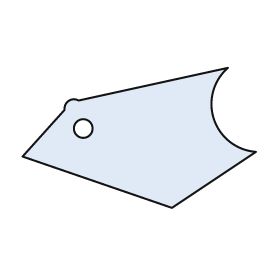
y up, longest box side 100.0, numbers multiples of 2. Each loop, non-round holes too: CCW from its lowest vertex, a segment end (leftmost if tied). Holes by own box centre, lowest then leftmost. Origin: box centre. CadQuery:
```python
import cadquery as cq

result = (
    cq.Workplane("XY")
    .moveTo(14.0, -30.0)
    .lineTo(50.0, -6.0)
    .threePointArc((32.0, 8.0), (38.0, 30.0))
    .lineTo(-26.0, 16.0)
    .threePointArc((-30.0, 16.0), (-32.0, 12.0))
    .lineTo(-50.0, -8.0)
    .close()
    .moveTo(-24.0, 4.0)
    .circle(4.0)
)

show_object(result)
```